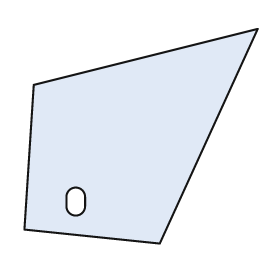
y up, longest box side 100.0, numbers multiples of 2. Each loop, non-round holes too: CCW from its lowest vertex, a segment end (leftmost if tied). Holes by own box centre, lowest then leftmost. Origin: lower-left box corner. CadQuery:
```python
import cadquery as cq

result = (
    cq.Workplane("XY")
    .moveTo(58.0, 0.0)
    .lineTo(100.0, 92.0)
    .lineTo(4.0, 68.0)
    .lineTo(0.0, 6.0)
    .close()
    .moveTo(18.0, 16.0)
    .threePointArc((22.0, 12.0), (26.0, 16.0))
    .lineTo(26.0, 20.0)
    .threePointArc((22.0, 24.0), (18.0, 20.0))
    .close()
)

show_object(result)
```